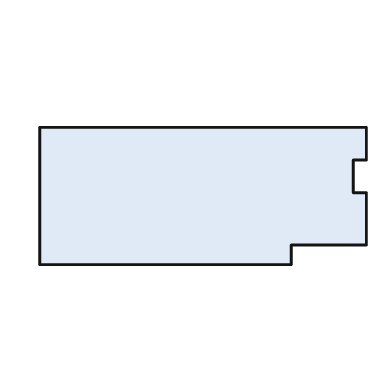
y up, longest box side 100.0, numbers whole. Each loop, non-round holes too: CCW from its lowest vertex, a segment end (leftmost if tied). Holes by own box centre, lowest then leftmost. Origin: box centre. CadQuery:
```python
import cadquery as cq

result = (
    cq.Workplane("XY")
    .moveTo(-50.0, -21.0)
    .lineTo(27.0, -21.0)
    .lineTo(27.0, -15.0)
    .lineTo(50.0, -15.0)
    .lineTo(50.0, 1.0)
    .lineTo(46.0, 1.0)
    .lineTo(46.0, 11.0)
    .lineTo(50.0, 11.0)
    .lineTo(50.0, 21.0)
    .lineTo(-50.0, 21.0)
    .close()
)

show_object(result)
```